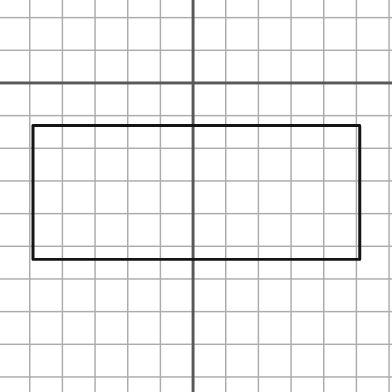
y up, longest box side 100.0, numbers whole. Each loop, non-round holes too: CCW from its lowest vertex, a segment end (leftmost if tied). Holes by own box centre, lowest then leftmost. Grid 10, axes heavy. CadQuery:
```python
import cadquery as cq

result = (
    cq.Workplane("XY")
    .moveTo(-49.0, -54.0)
    .lineTo(51.0, -54.0)
    .lineTo(51.0, -13.0)
    .lineTo(-49.0, -13.0)
    .close()
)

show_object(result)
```